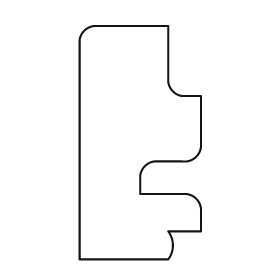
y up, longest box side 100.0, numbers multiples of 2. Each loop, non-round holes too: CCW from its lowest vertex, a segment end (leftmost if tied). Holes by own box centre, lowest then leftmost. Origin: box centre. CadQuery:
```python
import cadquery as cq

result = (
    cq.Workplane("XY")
    .moveTo(-26.0, -50.0)
    .lineTo(12.0, -50.0)
    .threePointArc((14.0, -44.0), (12.0, -38.0))
    .lineTo(26.0, -38.0)
    .lineTo(26.0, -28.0)
    .threePointArc((24.0, -24.0), (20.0, -22.0))
    .lineTo(0.0, -22.0)
    .lineTo(0.0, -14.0)
    .threePointArc((2.0, -10.0), (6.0, -8.0))
    .lineTo(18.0, -8.0)
    .threePointArc((24.0, -6.0), (26.0, 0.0))
    .lineTo(26.0, 20.0)
    .lineTo(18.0, 20.0)
    .threePointArc((14.0, 22.0), (12.0, 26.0))
    .lineTo(12.0, 50.0)
    .lineTo(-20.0, 50.0)
    .threePointArc((-24.0, 48.0), (-26.0, 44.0))
    .close()
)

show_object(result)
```